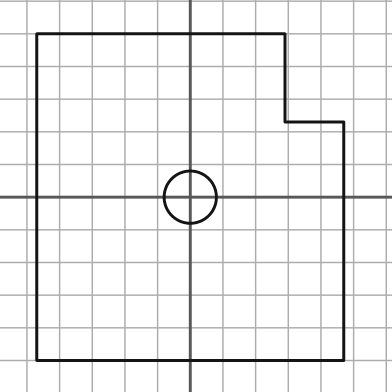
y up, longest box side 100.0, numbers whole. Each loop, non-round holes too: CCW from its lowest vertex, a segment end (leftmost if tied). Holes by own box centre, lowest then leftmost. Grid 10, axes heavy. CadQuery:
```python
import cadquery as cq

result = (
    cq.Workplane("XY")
    .moveTo(-47.0, -50.0)
    .lineTo(47.0, -50.0)
    .lineTo(47.0, 23.0)
    .lineTo(29.0, 23.0)
    .lineTo(29.0, 50.0)
    .lineTo(-47.0, 50.0)
    .close()
    .moveTo(0.0, 0.0)
    .circle(8.0)
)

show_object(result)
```